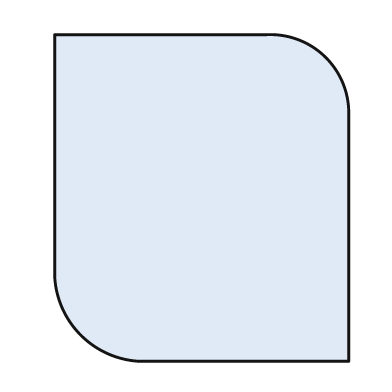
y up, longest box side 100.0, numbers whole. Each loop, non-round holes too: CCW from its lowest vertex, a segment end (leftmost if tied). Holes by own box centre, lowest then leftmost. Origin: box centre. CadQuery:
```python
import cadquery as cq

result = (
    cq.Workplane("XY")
    .moveTo(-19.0, -50.0)
    .lineTo(45.0, -50.0)
    .lineTo(45.0, 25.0)
    .threePointArc((38.0, 43.0), (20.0, 50.0))
    .lineTo(-45.0, 50.0)
    .lineTo(-45.0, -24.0)
    .threePointArc((-37.0, -42.0), (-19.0, -50.0))
    .close()
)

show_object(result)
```